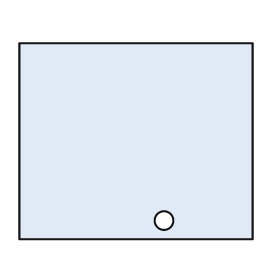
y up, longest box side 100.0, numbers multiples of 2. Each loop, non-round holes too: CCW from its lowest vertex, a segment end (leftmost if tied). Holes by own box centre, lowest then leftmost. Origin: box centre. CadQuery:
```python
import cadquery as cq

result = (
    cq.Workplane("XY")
    .moveTo(-50.0, -42.0)
    .lineTo(50.0, -42.0)
    .lineTo(50.0, 42.0)
    .lineTo(-50.0, 42.0)
    .close()
    .moveTo(12.0, -34.0)
    .circle(4.0)
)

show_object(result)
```